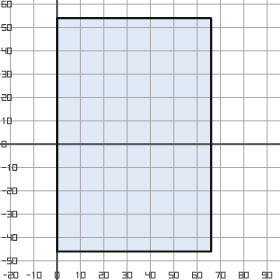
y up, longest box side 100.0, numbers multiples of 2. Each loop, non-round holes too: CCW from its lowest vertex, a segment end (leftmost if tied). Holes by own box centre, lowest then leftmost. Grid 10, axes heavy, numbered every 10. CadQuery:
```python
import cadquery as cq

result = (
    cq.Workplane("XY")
    .moveTo(0.0, -46.0)
    .lineTo(66.0, -46.0)
    .lineTo(66.0, 54.0)
    .lineTo(0.0, 54.0)
    .close()
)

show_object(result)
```